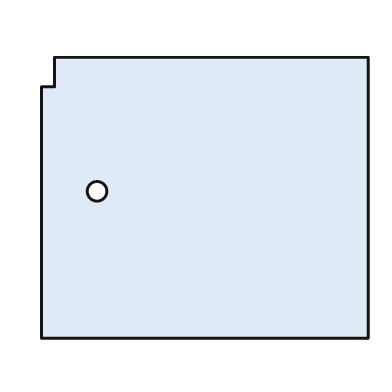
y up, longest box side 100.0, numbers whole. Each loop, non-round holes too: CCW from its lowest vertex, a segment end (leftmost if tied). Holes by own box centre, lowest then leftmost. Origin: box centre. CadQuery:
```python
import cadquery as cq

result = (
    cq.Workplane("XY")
    .moveTo(-50.0, -43.0)
    .lineTo(50.0, -43.0)
    .lineTo(50.0, 43.0)
    .lineTo(-46.0, 43.0)
    .lineTo(-46.0, 34.0)
    .lineTo(-50.0, 34.0)
    .close()
    .moveTo(-33.0, 2.0)
    .circle(3.0)
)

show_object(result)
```